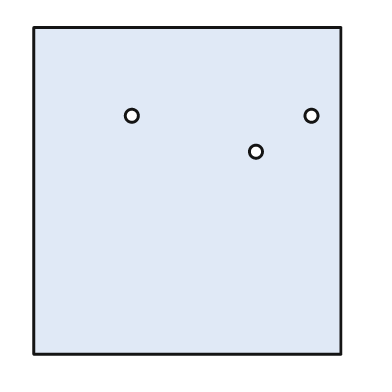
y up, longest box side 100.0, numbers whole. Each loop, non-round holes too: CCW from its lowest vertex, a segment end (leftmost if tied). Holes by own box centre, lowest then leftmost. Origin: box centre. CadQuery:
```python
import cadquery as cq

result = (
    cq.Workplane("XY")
    .moveTo(-47.0, -50.0)
    .lineTo(47.0, -50.0)
    .lineTo(47.0, 50.0)
    .lineTo(-47.0, 50.0)
    .close()
    .moveTo(21.0, 12.0)
    .circle(2.0)
    .moveTo(-17.0, 23.0)
    .circle(2.0)
    .moveTo(38.0, 23.0)
    .circle(2.0)
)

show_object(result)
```